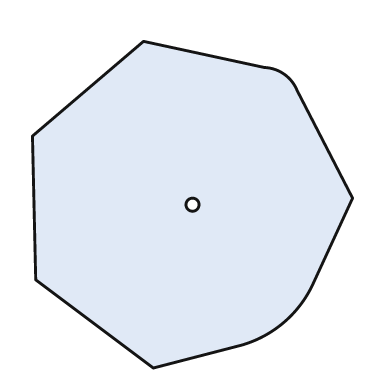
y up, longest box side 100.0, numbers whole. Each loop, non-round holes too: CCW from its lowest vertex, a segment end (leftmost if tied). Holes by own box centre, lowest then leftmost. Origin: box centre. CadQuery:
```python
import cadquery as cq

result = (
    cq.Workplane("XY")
    .moveTo(-12.0, -50.0)
    .lineTo(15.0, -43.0)
    .threePointArc((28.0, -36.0), (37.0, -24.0))
    .lineTo(49.0, 2.0)
    .lineTo(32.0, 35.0)
    .threePointArc((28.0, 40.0), (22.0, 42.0))
    .lineTo(-15.0, 50.0)
    .lineTo(-49.0, 21.0)
    .lineTo(-48.0, -23.0)
    .close()
    .moveTo(0.0, 0.0)
    .circle(2.0)
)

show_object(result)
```